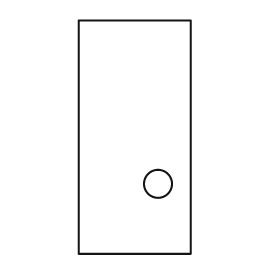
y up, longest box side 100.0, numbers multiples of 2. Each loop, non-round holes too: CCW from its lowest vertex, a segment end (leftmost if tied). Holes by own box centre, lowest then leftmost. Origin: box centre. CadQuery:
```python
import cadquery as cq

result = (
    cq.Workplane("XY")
    .moveTo(-24.0, -50.0)
    .lineTo(24.0, -50.0)
    .lineTo(24.0, 50.0)
    .lineTo(-24.0, 50.0)
    .close()
    .moveTo(10.0, -20.0)
    .circle(6.0)
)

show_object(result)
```